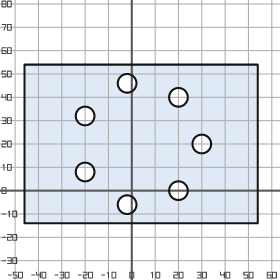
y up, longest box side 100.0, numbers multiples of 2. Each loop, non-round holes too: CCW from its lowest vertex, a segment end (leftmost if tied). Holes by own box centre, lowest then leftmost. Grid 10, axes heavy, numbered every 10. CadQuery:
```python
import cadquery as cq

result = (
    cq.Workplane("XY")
    .moveTo(-46.0, -14.0)
    .lineTo(54.0, -14.0)
    .lineTo(54.0, 54.0)
    .lineTo(-46.0, 54.0)
    .close()
    .moveTo(-2.0, -6.0)
    .circle(4.0)
    .moveTo(20.0, 0.0)
    .circle(4.0)
    .moveTo(-20.0, 8.0)
    .circle(4.0)
    .moveTo(30.0, 20.0)
    .circle(4.0)
    .moveTo(-20.0, 32.0)
    .circle(4.0)
    .moveTo(20.0, 40.0)
    .circle(4.0)
    .moveTo(-2.0, 46.0)
    .circle(4.0)
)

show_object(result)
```